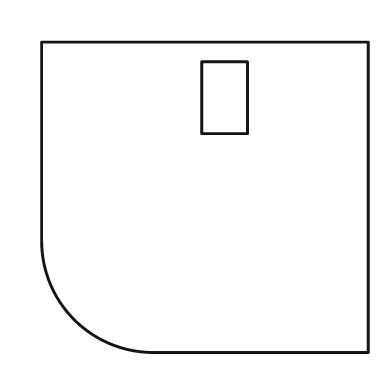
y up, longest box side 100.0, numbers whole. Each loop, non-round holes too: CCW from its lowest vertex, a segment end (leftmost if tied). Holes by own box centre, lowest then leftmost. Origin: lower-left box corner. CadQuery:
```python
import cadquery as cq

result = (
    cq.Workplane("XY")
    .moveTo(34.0, 0.0)
    .lineTo(100.0, 0.0)
    .lineTo(100.0, 95.0)
    .lineTo(0.0, 95.0)
    .lineTo(0.0, 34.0)
    .threePointArc((10.0, 10.0), (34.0, 0.0))
    .close()
    .moveTo(49.0, 67.0)
    .lineTo(63.0, 67.0)
    .lineTo(63.0, 89.0)
    .lineTo(49.0, 89.0)
    .close()
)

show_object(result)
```